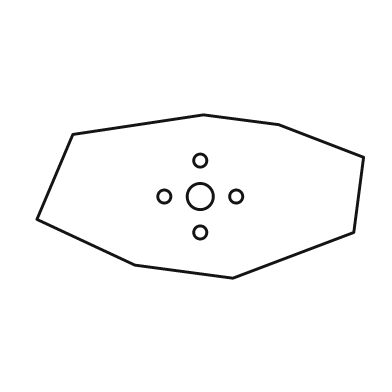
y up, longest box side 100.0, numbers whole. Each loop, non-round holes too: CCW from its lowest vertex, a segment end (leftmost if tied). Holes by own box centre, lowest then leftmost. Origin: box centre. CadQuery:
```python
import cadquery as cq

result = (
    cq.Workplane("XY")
    .moveTo(10.0, -25.0)
    .lineTo(47.0, -11.0)
    .lineTo(50.0, 12.0)
    .lineTo(24.0, 22.0)
    .lineTo(1.0, 25.0)
    .lineTo(-39.0, 19.0)
    .lineTo(-50.0, -7.0)
    .lineTo(-20.0, -21.0)
    .close()
    .moveTo(0.0, -11.0)
    .circle(2.0)
    .moveTo(-11.0, 0.0)
    .circle(2.0)
    .moveTo(0.0, 0.0)
    .circle(4.0)
    .moveTo(11.0, 0.0)
    .circle(2.0)
    .moveTo(0.0, 11.0)
    .circle(2.0)
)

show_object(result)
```